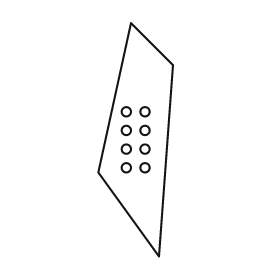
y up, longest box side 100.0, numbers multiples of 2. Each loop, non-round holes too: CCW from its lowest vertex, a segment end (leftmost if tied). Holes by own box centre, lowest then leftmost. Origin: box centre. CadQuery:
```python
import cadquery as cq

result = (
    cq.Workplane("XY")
    .moveTo(10.0, -50.0)
    .lineTo(16.0, 32.0)
    .lineTo(-2.0, 50.0)
    .lineTo(-16.0, -14.0)
    .close()
    .moveTo(-4.0, -12.0)
    .circle(2.0)
    .moveTo(4.0, -12.0)
    .circle(2.0)
    .moveTo(-4.0, -4.0)
    .circle(2.0)
    .moveTo(4.0, -4.0)
    .circle(2.0)
    .moveTo(-4.0, 4.0)
    .circle(2.0)
    .moveTo(4.0, 4.0)
    .circle(2.0)
    .moveTo(-4.0, 12.0)
    .circle(2.0)
    .moveTo(4.0, 12.0)
    .circle(2.0)
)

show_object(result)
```